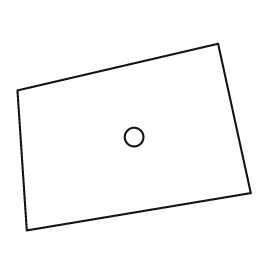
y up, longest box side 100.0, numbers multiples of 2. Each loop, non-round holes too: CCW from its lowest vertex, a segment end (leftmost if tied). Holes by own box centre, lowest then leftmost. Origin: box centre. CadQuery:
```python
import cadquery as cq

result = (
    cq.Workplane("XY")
    .moveTo(-46.0, -40.0)
    .lineTo(50.0, -24.0)
    .lineTo(36.0, 40.0)
    .lineTo(-50.0, 20.0)
    .close()
    .moveTo(0.0, 0.0)
    .circle(4.0)
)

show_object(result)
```